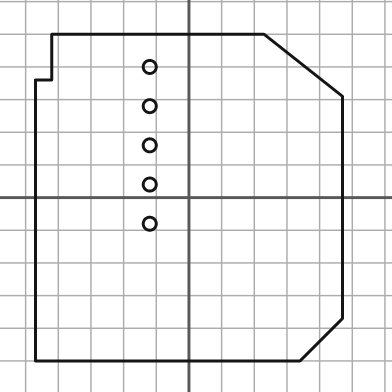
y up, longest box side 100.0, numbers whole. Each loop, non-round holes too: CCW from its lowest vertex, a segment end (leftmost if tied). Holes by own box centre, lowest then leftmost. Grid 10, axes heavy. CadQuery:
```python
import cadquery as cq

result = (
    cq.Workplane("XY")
    .moveTo(-47.0, -50.0)
    .lineTo(34.0, -50.0)
    .lineTo(47.0, -37.0)
    .lineTo(47.0, 31.0)
    .lineTo(23.0, 50.0)
    .lineTo(-42.0, 50.0)
    .lineTo(-42.0, 36.0)
    .lineTo(-47.0, 36.0)
    .close()
    .moveTo(-12.0, -8.0)
    .circle(2.0)
    .moveTo(-12.0, 4.0)
    .circle(2.0)
    .moveTo(-12.0, 16.0)
    .circle(2.0)
    .moveTo(-12.0, 28.0)
    .circle(2.0)
    .moveTo(-12.0, 40.0)
    .circle(2.0)
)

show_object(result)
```